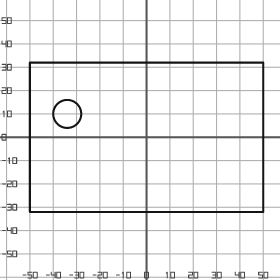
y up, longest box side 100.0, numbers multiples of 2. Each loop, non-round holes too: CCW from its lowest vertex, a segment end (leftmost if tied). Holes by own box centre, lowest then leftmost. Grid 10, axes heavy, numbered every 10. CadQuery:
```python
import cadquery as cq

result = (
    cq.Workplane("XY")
    .moveTo(-50.0, -32.0)
    .lineTo(50.0, -32.0)
    .lineTo(50.0, 32.0)
    .lineTo(-50.0, 32.0)
    .close()
    .moveTo(-34.0, 10.0)
    .circle(6.0)
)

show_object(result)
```